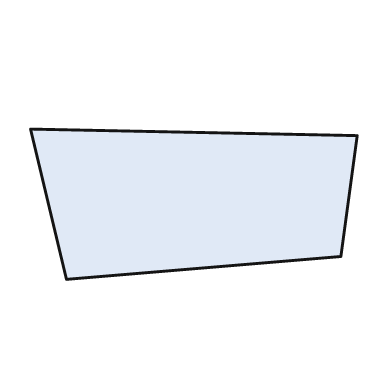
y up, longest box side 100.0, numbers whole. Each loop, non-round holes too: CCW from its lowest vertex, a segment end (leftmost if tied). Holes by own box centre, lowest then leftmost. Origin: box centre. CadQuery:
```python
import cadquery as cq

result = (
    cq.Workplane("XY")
    .moveTo(-39.0, -23.0)
    .lineTo(45.0, -16.0)
    .lineTo(50.0, 21.0)
    .lineTo(-50.0, 23.0)
    .close()
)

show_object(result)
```